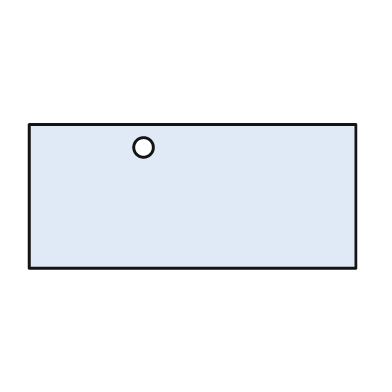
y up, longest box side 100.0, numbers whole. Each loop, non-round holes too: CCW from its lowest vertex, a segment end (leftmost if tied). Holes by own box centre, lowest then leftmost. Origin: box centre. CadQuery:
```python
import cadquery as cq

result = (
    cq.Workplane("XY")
    .moveTo(-50.0, -22.0)
    .lineTo(50.0, -22.0)
    .lineTo(50.0, 22.0)
    .lineTo(-50.0, 22.0)
    .close()
    .moveTo(-15.0, 15.0)
    .circle(3.0)
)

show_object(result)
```